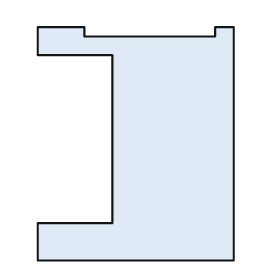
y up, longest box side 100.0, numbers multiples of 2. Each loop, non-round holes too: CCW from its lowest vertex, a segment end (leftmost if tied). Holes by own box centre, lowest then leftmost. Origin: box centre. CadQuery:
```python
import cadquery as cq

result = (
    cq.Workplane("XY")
    .moveTo(-42.0, -50.0)
    .lineTo(42.0, -50.0)
    .lineTo(42.0, 50.0)
    .lineTo(34.0, 50.0)
    .lineTo(34.0, 46.0)
    .lineTo(-22.0, 46.0)
    .lineTo(-22.0, 50.0)
    .lineTo(-42.0, 50.0)
    .lineTo(-42.0, 38.0)
    .lineTo(-10.0, 38.0)
    .lineTo(-10.0, -34.0)
    .lineTo(-42.0, -34.0)
    .close()
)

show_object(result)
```